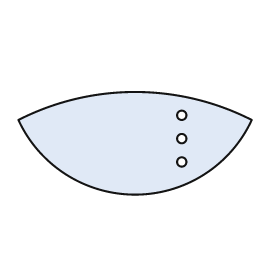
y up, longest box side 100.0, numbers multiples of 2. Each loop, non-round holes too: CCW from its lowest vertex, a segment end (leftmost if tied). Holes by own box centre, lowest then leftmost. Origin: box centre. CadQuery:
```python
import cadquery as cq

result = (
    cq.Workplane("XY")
    .moveTo(-50.0, 10.0)
    .threePointArc((0.0, -22.0), (50.0, 10.0))
    .threePointArc((0.0, 22.0), (-50.0, 10.0))
    .close()
    .moveTo(20.0, -8.0)
    .circle(2.0)
    .moveTo(20.0, 2.0)
    .circle(2.0)
    .moveTo(20.0, 12.0)
    .circle(2.0)
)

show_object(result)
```